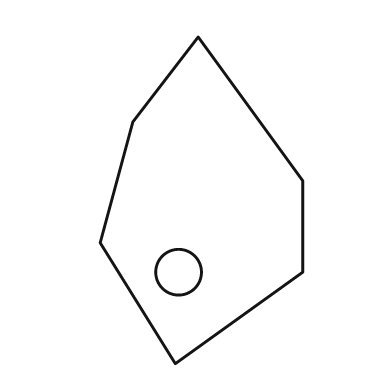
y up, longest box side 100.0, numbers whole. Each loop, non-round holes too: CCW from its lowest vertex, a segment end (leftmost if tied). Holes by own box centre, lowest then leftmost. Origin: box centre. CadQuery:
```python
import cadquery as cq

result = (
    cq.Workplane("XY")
    .moveTo(-8.0, -50.0)
    .lineTo(31.0, -22.0)
    .lineTo(31.0, 6.0)
    .lineTo(-1.0, 50.0)
    .lineTo(-21.0, 24.0)
    .lineTo(-31.0, -13.0)
    .close()
    .moveTo(-7.0, -22.0)
    .circle(7.0)
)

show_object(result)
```